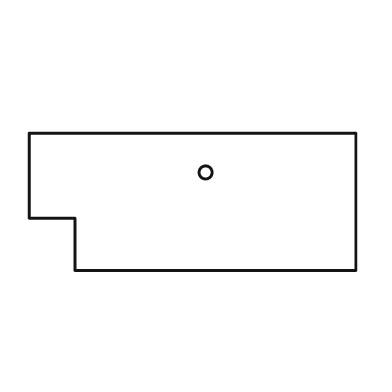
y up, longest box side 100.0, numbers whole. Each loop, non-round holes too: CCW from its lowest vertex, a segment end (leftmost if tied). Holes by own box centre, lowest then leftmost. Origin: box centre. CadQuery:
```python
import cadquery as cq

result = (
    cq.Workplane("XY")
    .moveTo(-36.0, -21.0)
    .lineTo(50.0, -21.0)
    .lineTo(50.0, 21.0)
    .lineTo(-50.0, 21.0)
    .lineTo(-50.0, -5.0)
    .lineTo(-36.0, -5.0)
    .close()
    .moveTo(4.0, 9.0)
    .circle(2.0)
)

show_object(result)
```